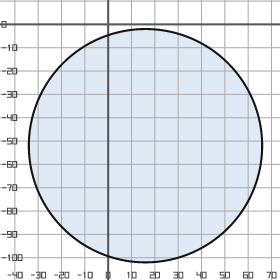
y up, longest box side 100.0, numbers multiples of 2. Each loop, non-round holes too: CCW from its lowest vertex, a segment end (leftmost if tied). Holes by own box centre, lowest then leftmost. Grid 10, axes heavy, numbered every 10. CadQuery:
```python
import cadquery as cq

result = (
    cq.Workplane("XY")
    .moveTo(16.0, -52.0)
    .circle(50.0)
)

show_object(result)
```